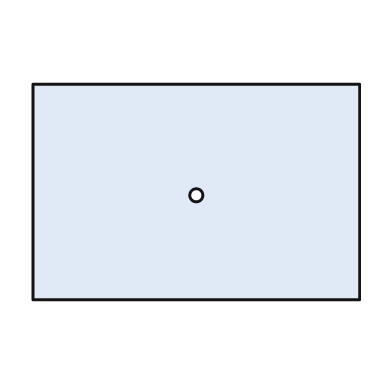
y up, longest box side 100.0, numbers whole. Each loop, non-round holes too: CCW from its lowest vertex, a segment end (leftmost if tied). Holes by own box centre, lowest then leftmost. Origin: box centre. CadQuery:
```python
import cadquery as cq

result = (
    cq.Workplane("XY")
    .moveTo(-50.0, -33.0)
    .lineTo(50.0, -33.0)
    .lineTo(50.0, 33.0)
    .lineTo(-50.0, 33.0)
    .close()
    .moveTo(0.0, -1.0)
    .circle(2.0)
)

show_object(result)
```